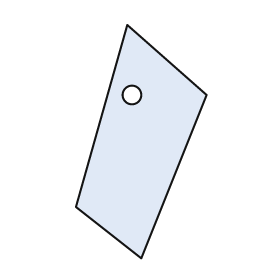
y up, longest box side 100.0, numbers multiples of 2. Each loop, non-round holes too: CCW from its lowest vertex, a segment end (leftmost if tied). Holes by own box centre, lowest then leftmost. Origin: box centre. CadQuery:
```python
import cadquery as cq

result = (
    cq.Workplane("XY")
    .moveTo(0.0, -50.0)
    .lineTo(28.0, 20.0)
    .lineTo(-6.0, 50.0)
    .lineTo(-28.0, -28.0)
    .close()
    .moveTo(-4.0, 20.0)
    .circle(4.0)
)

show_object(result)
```